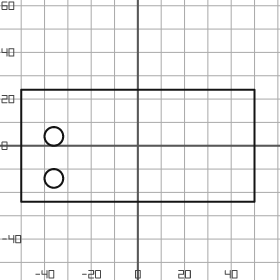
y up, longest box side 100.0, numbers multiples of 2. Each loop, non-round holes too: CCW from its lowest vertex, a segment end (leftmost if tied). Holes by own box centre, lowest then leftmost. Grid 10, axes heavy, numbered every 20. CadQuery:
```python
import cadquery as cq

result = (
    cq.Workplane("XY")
    .moveTo(-50.0, -24.0)
    .lineTo(50.0, -24.0)
    .lineTo(50.0, 24.0)
    .lineTo(-50.0, 24.0)
    .close()
    .moveTo(-36.0, -14.0)
    .circle(4.0)
    .moveTo(-36.0, 4.0)
    .circle(4.0)
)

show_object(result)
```